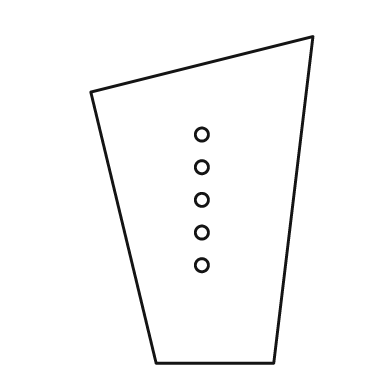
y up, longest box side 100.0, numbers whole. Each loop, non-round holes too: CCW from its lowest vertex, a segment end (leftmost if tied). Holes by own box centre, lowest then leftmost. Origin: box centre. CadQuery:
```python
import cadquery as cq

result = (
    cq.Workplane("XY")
    .moveTo(-14.0, -50.0)
    .lineTo(22.0, -50.0)
    .lineTo(34.0, 50.0)
    .lineTo(-34.0, 33.0)
    .close()
    .moveTo(0.0, -20.0)
    .circle(2.0)
    .moveTo(0.0, -10.0)
    .circle(2.0)
    .moveTo(0.0, 0.0)
    .circle(2.0)
    .moveTo(0.0, 10.0)
    .circle(2.0)
    .moveTo(0.0, 20.0)
    .circle(2.0)
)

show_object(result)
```